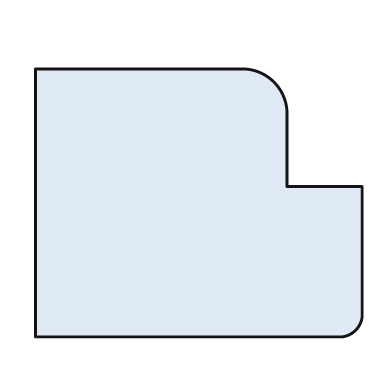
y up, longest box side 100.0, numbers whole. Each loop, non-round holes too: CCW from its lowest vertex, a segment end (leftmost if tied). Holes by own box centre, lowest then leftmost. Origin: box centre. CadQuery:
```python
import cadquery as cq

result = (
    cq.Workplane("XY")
    .moveTo(-50.0, -41.0)
    .lineTo(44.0, -41.0)
    .threePointArc((48.0, -39.0), (50.0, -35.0))
    .lineTo(50.0, 5.0)
    .lineTo(27.0, 5.0)
    .lineTo(27.0, 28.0)
    .threePointArc((23.0, 37.0), (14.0, 41.0))
    .lineTo(-50.0, 41.0)
    .close()
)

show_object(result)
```